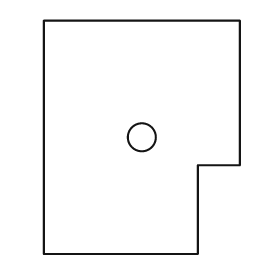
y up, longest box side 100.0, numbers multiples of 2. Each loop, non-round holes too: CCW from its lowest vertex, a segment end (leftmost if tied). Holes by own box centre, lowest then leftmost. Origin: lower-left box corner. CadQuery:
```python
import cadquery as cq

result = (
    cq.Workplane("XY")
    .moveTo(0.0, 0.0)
    .lineTo(66.0, 0.0)
    .lineTo(66.0, 38.0)
    .lineTo(84.0, 38.0)
    .lineTo(84.0, 100.0)
    .lineTo(0.0, 100.0)
    .close()
    .moveTo(42.0, 50.0)
    .circle(6.0)
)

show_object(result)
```